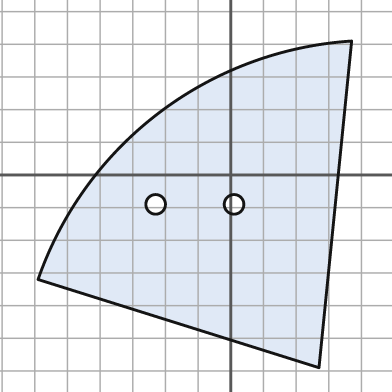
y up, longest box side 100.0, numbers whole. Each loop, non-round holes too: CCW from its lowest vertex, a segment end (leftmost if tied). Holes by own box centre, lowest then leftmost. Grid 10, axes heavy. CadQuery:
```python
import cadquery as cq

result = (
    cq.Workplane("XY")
    .moveTo(27.0, -59.0)
    .lineTo(37.0, 41.0)
    .threePointArc((-22.0, 19.0), (-59.0, -32.0))
    .close()
    .moveTo(-23.0, -9.0)
    .circle(3.0)
    .moveTo(1.0, -9.0)
    .circle(3.0)
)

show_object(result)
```